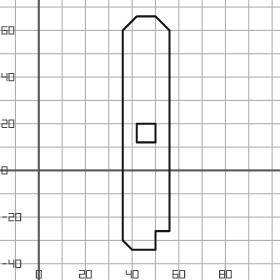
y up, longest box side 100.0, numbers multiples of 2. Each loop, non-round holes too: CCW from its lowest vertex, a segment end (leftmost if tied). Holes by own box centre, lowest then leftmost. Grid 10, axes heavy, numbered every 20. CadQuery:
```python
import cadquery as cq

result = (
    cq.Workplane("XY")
    .moveTo(40.0, -34.0)
    .lineTo(50.0, -34.0)
    .lineTo(50.0, -26.0)
    .lineTo(56.0, -26.0)
    .lineTo(56.0, 60.0)
    .lineTo(50.0, 66.0)
    .lineTo(42.0, 66.0)
    .lineTo(36.0, 60.0)
    .lineTo(36.0, -30.0)
    .close()
    .moveTo(42.0, 12.0)
    .lineTo(50.0, 12.0)
    .lineTo(50.0, 20.0)
    .lineTo(42.0, 20.0)
    .close()
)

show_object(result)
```